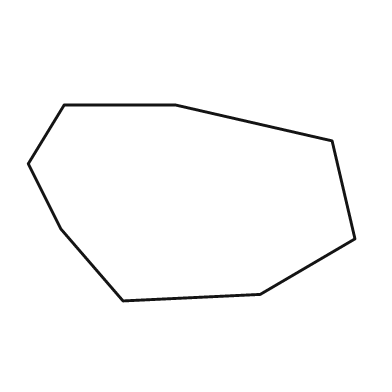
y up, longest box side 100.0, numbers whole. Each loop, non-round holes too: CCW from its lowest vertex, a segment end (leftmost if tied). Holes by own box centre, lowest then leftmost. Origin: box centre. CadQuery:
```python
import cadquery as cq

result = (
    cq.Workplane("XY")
    .moveTo(-21.0, -30.0)
    .lineTo(21.0, -28.0)
    .lineTo(50.0, -11.0)
    .lineTo(43.0, 19.0)
    .lineTo(-5.0, 30.0)
    .lineTo(-39.0, 30.0)
    .lineTo(-50.0, 12.0)
    .lineTo(-40.0, -8.0)
    .close()
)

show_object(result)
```